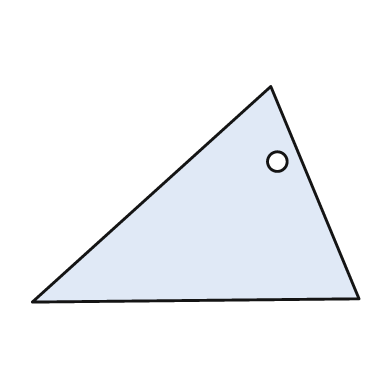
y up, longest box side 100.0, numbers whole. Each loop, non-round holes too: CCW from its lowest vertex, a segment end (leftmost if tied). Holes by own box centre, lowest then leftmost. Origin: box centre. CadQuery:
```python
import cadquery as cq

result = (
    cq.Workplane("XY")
    .moveTo(-50.0, -33.0)
    .lineTo(50.0, -32.0)
    .lineTo(23.0, 33.0)
    .close()
    .moveTo(25.0, 10.0)
    .circle(3.0)
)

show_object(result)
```